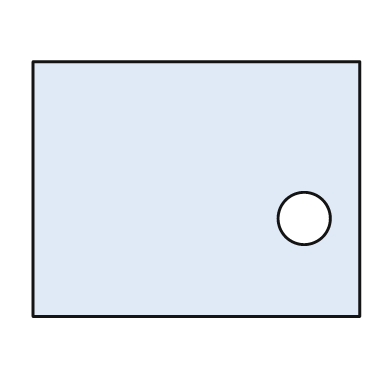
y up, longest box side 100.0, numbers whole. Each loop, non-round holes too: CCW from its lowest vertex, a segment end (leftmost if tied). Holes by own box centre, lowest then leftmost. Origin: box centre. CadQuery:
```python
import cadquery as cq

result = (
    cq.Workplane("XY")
    .moveTo(-50.0, -39.0)
    .lineTo(50.0, -39.0)
    .lineTo(50.0, 39.0)
    .lineTo(-50.0, 39.0)
    .close()
    .moveTo(33.0, -9.0)
    .circle(8.0)
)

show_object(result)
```